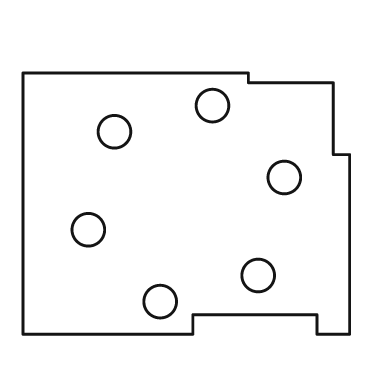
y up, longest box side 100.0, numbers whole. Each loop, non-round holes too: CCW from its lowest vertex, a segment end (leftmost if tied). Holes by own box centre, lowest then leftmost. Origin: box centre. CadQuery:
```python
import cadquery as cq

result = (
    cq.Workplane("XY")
    .moveTo(-50.0, -40.0)
    .lineTo(2.0, -40.0)
    .lineTo(2.0, -34.0)
    .lineTo(40.0, -34.0)
    .lineTo(40.0, -40.0)
    .lineTo(50.0, -40.0)
    .lineTo(50.0, 15.0)
    .lineTo(45.0, 15.0)
    .lineTo(45.0, 37.0)
    .lineTo(19.0, 37.0)
    .lineTo(19.0, 40.0)
    .lineTo(-50.0, 40.0)
    .close()
    .moveTo(-8.0, -30.0)
    .circle(5.0)
    .moveTo(22.0, -22.0)
    .circle(5.0)
    .moveTo(-30.0, -8.0)
    .circle(5.0)
    .moveTo(30.0, 8.0)
    .circle(5.0)
    .moveTo(-22.0, 22.0)
    .circle(5.0)
    .moveTo(8.0, 30.0)
    .circle(5.0)
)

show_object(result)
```